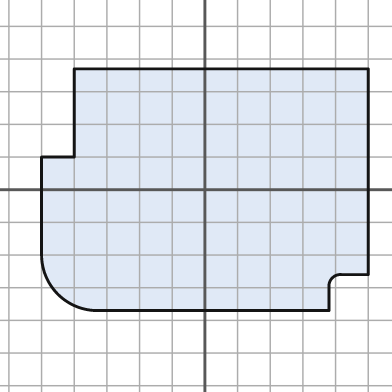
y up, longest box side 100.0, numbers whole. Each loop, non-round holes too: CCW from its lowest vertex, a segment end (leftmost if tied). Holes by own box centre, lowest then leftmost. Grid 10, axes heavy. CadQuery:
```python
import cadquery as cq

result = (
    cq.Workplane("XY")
    .moveTo(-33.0, -37.0)
    .lineTo(38.0, -37.0)
    .lineTo(38.0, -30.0)
    .threePointArc((39.0, -27.0), (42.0, -26.0))
    .lineTo(50.0, -26.0)
    .lineTo(50.0, 37.0)
    .lineTo(-40.0, 37.0)
    .lineTo(-40.0, 10.0)
    .lineTo(-50.0, 10.0)
    .lineTo(-50.0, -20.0)
    .threePointArc((-45.0, -32.0), (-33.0, -37.0))
    .close()
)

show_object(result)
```